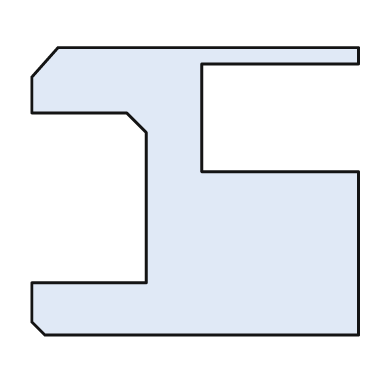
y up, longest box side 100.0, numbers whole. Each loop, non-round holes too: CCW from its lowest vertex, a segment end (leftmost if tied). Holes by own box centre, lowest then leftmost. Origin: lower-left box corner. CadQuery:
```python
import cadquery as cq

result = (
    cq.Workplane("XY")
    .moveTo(4.0, 0.0)
    .lineTo(100.0, 0.0)
    .lineTo(100.0, 50.0)
    .lineTo(52.0, 50.0)
    .lineTo(52.0, 83.0)
    .lineTo(100.0, 83.0)
    .lineTo(100.0, 88.0)
    .lineTo(8.0, 88.0)
    .lineTo(0.0, 79.0)
    .lineTo(0.0, 68.0)
    .lineTo(29.0, 68.0)
    .lineTo(35.0, 62.0)
    .lineTo(35.0, 16.0)
    .lineTo(0.0, 16.0)
    .lineTo(0.0, 4.0)
    .close()
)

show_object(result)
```